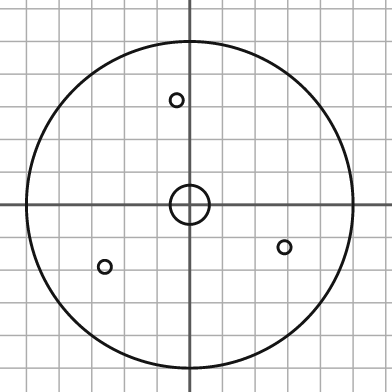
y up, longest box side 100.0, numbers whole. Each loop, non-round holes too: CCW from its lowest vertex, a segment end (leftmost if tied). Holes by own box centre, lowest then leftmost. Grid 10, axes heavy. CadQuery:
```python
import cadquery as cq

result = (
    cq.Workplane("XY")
    .moveTo(0.0, 0.0)
    .circle(50.0)
    .moveTo(-26.0, -19.0)
    .circle(2.0)
    .moveTo(29.0, -13.0)
    .circle(2.0)
    .moveTo(0.0, 0.0)
    .circle(6.0)
    .moveTo(-4.0, 32.0)
    .circle(2.0)
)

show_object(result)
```